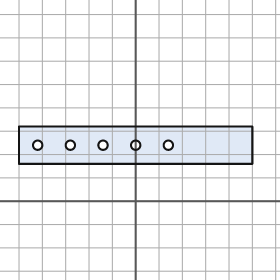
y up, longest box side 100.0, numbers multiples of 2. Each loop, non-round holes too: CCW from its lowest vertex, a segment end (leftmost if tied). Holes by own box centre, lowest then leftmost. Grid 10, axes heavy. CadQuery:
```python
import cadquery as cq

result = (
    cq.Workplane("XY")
    .moveTo(-50.0, 16.0)
    .lineTo(50.0, 16.0)
    .lineTo(50.0, 32.0)
    .lineTo(-50.0, 32.0)
    .close()
    .moveTo(-42.0, 24.0)
    .circle(2.0)
    .moveTo(-28.0, 24.0)
    .circle(2.0)
    .moveTo(-14.0, 24.0)
    .circle(2.0)
    .moveTo(0.0, 24.0)
    .circle(2.0)
    .moveTo(14.0, 24.0)
    .circle(2.0)
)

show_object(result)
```